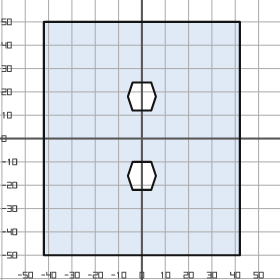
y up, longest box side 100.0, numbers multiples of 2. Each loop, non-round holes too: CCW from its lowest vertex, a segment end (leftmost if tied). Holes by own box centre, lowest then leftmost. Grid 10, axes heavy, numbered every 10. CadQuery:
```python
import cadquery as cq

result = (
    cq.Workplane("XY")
    .moveTo(-42.0, -50.0)
    .lineTo(42.0, -50.0)
    .lineTo(42.0, 50.0)
    .lineTo(-42.0, 50.0)
    .close()
    .moveTo(-4.0, -22.0)
    .lineTo(4.0, -22.0)
    .lineTo(6.0, -16.0)
    .lineTo(4.0, -10.0)
    .lineTo(-4.0, -10.0)
    .lineTo(-6.0, -16.0)
    .close()
    .moveTo(-4.0, 12.0)
    .lineTo(4.0, 12.0)
    .lineTo(6.0, 18.0)
    .lineTo(4.0, 24.0)
    .lineTo(-4.0, 24.0)
    .lineTo(-6.0, 18.0)
    .close()
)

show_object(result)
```